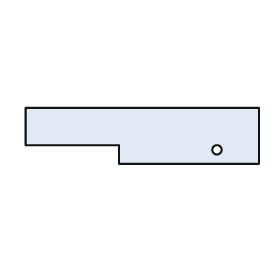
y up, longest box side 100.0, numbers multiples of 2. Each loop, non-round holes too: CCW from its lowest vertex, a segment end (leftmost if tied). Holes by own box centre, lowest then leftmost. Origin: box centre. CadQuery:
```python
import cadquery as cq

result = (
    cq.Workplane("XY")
    .moveTo(-10.0, -12.0)
    .lineTo(50.0, -12.0)
    .lineTo(50.0, 12.0)
    .lineTo(-50.0, 12.0)
    .lineTo(-50.0, -4.0)
    .lineTo(-10.0, -4.0)
    .close()
    .moveTo(32.0, -6.0)
    .circle(2.0)
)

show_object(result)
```